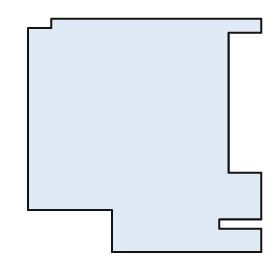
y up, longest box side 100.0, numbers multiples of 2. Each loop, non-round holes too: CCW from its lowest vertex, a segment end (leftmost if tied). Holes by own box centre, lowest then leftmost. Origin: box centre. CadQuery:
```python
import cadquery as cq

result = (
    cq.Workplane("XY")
    .moveTo(-14.0, -50.0)
    .lineTo(50.0, -50.0)
    .lineTo(50.0, -40.0)
    .lineTo(32.0, -40.0)
    .lineTo(32.0, -36.0)
    .lineTo(50.0, -36.0)
    .lineTo(50.0, -16.0)
    .lineTo(36.0, -16.0)
    .lineTo(36.0, 44.0)
    .lineTo(50.0, 44.0)
    .lineTo(50.0, 50.0)
    .lineTo(-40.0, 50.0)
    .lineTo(-40.0, 46.0)
    .lineTo(-50.0, 46.0)
    .lineTo(-50.0, -32.0)
    .lineTo(-14.0, -32.0)
    .close()
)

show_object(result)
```